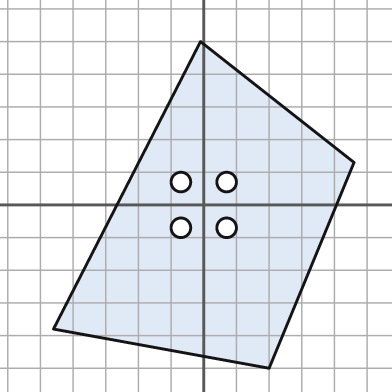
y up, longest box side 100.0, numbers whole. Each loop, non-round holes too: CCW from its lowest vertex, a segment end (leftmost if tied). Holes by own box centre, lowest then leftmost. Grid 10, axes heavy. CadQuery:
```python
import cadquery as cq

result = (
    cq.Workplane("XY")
    .moveTo(20.0, -50.0)
    .lineTo(46.0, 13.0)
    .lineTo(-1.0, 50.0)
    .lineTo(-46.0, -38.0)
    .close()
    .moveTo(-7.0, -7.0)
    .circle(3.0)
    .moveTo(7.0, -7.0)
    .circle(3.0)
    .moveTo(-7.0, 7.0)
    .circle(3.0)
    .moveTo(7.0, 7.0)
    .circle(3.0)
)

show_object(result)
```